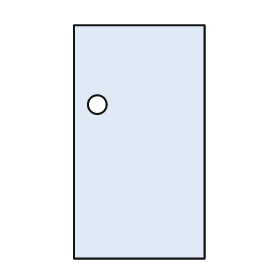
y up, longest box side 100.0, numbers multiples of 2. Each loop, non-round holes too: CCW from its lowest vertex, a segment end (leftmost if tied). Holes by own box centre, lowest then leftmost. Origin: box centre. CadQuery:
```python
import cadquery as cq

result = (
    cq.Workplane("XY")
    .moveTo(-28.0, -50.0)
    .lineTo(28.0, -50.0)
    .lineTo(28.0, 50.0)
    .lineTo(-28.0, 50.0)
    .close()
    .moveTo(-18.0, 16.0)
    .circle(4.0)
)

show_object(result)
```